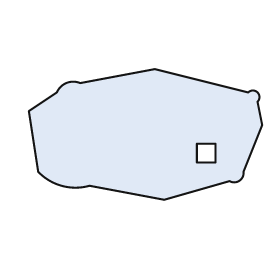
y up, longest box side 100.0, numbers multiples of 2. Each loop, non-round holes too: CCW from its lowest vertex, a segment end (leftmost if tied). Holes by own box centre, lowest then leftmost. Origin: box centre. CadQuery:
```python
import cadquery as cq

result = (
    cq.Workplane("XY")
    .moveTo(8.0, -28.0)
    .lineTo(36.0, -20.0)
    .threePointArc((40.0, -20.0), (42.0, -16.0))
    .lineTo(50.0, 4.0)
    .lineTo(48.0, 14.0)
    .threePointArc((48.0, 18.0), (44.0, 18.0))
    .lineTo(4.0, 28.0)
    .lineTo(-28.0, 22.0)
    .threePointArc((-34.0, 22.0), (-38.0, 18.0))
    .lineTo(-50.0, 10.0)
    .lineTo(-46.0, -16.0)
    .threePointArc((-36.0, -22.0), (-24.0, -22.0))
    .close()
    .moveTo(22.0, -12.0)
    .lineTo(30.0, -12.0)
    .lineTo(30.0, -4.0)
    .lineTo(22.0, -4.0)
    .close()
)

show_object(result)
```